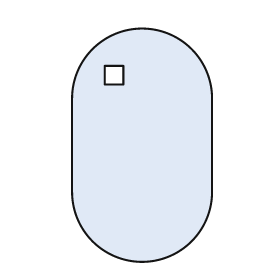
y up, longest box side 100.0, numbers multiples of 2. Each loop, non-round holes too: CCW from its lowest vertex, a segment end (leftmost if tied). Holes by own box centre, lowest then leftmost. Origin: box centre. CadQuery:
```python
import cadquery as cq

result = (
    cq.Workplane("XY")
    .moveTo(-30.0, -20.0)
    .threePointArc((0.0, -50.0), (30.0, -20.0))
    .lineTo(30.0, 20.0)
    .threePointArc((0.0, 50.0), (-30.0, 20.0))
    .close()
    .moveTo(-16.0, 26.0)
    .lineTo(-8.0, 26.0)
    .lineTo(-8.0, 34.0)
    .lineTo(-16.0, 34.0)
    .close()
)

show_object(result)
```